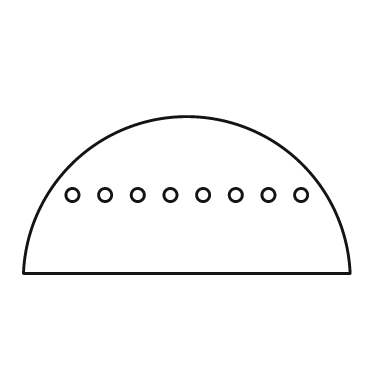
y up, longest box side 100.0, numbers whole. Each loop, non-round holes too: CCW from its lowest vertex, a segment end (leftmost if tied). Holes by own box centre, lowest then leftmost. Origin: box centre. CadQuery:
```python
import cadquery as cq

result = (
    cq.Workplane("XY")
    .moveTo(-50.0, -24.0)
    .lineTo(50.0, -24.0)
    .threePointArc((0.0, 24.0), (-50.0, -24.0))
    .close()
    .moveTo(-35.0, 0.0)
    .circle(2.0)
    .moveTo(-25.0, 0.0)
    .circle(2.0)
    .moveTo(-15.0, 0.0)
    .circle(2.0)
    .moveTo(-5.0, 0.0)
    .circle(2.0)
    .moveTo(5.0, 0.0)
    .circle(2.0)
    .moveTo(15.0, 0.0)
    .circle(2.0)
    .moveTo(25.0, 0.0)
    .circle(2.0)
    .moveTo(35.0, 0.0)
    .circle(2.0)
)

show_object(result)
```